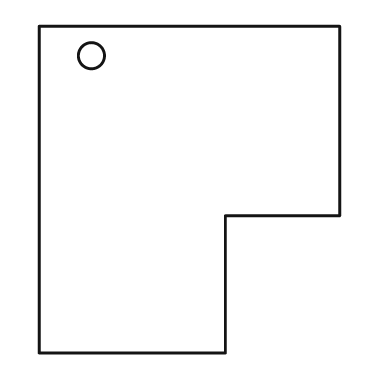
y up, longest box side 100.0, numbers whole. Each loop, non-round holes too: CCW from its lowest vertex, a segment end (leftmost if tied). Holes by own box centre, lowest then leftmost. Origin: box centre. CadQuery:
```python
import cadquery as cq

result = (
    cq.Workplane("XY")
    .moveTo(-46.0, -50.0)
    .lineTo(11.0, -50.0)
    .lineTo(11.0, -8.0)
    .lineTo(46.0, -8.0)
    .lineTo(46.0, 50.0)
    .lineTo(-46.0, 50.0)
    .close()
    .moveTo(-30.0, 41.0)
    .circle(4.0)
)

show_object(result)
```